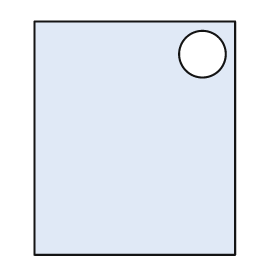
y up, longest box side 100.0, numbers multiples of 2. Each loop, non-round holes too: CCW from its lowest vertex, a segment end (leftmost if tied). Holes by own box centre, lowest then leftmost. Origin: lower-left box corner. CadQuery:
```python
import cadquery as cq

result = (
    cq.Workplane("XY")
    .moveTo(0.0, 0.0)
    .lineTo(86.0, 0.0)
    .lineTo(86.0, 100.0)
    .lineTo(0.0, 100.0)
    .close()
    .moveTo(72.0, 86.0)
    .circle(10.0)
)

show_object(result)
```